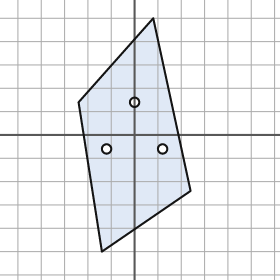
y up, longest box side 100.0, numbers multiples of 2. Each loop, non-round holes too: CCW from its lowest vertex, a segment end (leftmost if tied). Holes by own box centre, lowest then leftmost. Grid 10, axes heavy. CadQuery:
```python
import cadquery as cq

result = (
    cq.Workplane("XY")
    .moveTo(-14.0, -50.0)
    .lineTo(24.0, -24.0)
    .lineTo(8.0, 50.0)
    .lineTo(-24.0, 14.0)
    .close()
    .moveTo(-12.0, -6.0)
    .circle(2.0)
    .moveTo(12.0, -6.0)
    .circle(2.0)
    .moveTo(0.0, 14.0)
    .circle(2.0)
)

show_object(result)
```